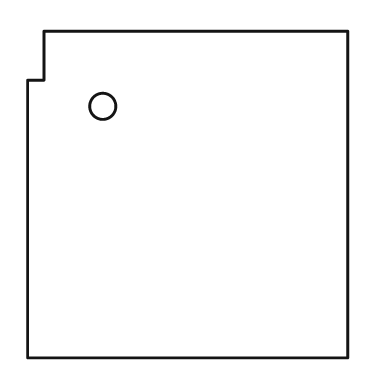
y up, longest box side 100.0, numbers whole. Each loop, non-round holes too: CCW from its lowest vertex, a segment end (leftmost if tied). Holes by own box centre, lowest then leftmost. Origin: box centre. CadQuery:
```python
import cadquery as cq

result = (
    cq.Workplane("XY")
    .moveTo(-49.0, -50.0)
    .lineTo(49.0, -50.0)
    .lineTo(49.0, 50.0)
    .lineTo(-44.0, 50.0)
    .lineTo(-44.0, 35.0)
    .lineTo(-49.0, 35.0)
    .close()
    .moveTo(-26.0, 27.0)
    .circle(4.0)
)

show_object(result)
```